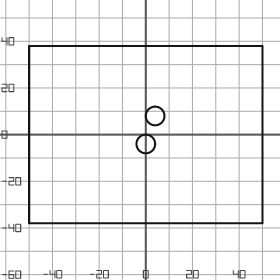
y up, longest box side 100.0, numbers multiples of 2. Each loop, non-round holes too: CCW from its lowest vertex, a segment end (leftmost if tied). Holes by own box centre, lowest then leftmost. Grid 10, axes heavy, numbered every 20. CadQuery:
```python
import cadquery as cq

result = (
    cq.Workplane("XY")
    .moveTo(-50.0, -38.0)
    .lineTo(50.0, -38.0)
    .lineTo(50.0, 38.0)
    .lineTo(-50.0, 38.0)
    .close()
    .moveTo(0.0, -4.0)
    .circle(4.0)
    .moveTo(4.0, 8.0)
    .circle(4.0)
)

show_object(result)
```